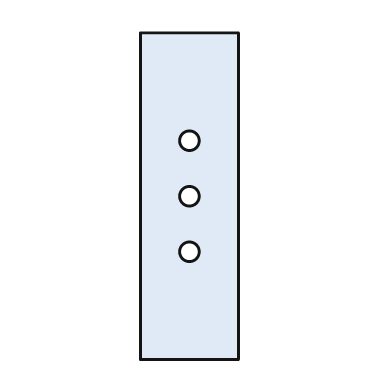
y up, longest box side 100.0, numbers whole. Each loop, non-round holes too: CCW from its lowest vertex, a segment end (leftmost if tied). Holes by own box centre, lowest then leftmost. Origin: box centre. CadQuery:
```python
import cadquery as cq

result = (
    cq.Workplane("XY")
    .moveTo(-15.0, -50.0)
    .lineTo(15.0, -50.0)
    .lineTo(15.0, 50.0)
    .lineTo(-15.0, 50.0)
    .close()
    .moveTo(0.0, -17.0)
    .circle(3.0)
    .moveTo(0.0, 0.0)
    .circle(3.0)
    .moveTo(0.0, 17.0)
    .circle(3.0)
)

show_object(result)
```